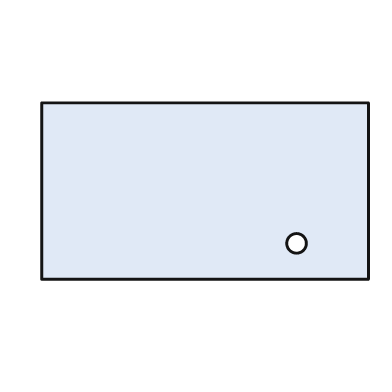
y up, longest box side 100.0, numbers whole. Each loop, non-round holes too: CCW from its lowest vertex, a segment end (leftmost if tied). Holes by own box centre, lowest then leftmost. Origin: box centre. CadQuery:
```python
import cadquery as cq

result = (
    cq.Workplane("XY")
    .moveTo(-50.0, -27.0)
    .lineTo(50.0, -27.0)
    .lineTo(50.0, 27.0)
    .lineTo(-50.0, 27.0)
    .close()
    .moveTo(28.0, -16.0)
    .circle(3.0)
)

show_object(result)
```